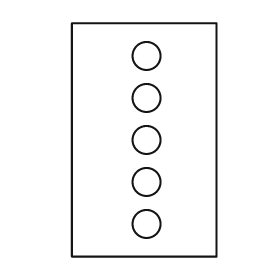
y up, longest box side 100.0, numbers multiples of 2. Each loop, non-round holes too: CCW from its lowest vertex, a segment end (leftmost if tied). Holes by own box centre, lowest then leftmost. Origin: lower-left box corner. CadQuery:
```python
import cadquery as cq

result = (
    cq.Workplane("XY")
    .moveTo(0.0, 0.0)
    .lineTo(62.0, 0.0)
    .lineTo(62.0, 100.0)
    .lineTo(0.0, 100.0)
    .close()
    .moveTo(32.0, 14.0)
    .circle(6.0)
    .moveTo(32.0, 32.0)
    .circle(6.0)
    .moveTo(32.0, 50.0)
    .circle(6.0)
    .moveTo(32.0, 68.0)
    .circle(6.0)
    .moveTo(32.0, 86.0)
    .circle(6.0)
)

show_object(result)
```